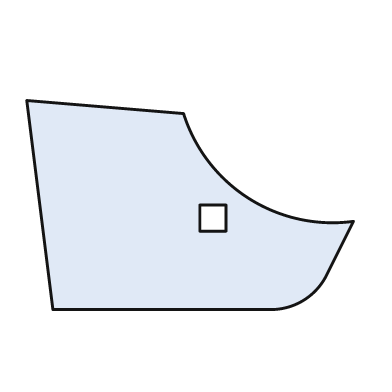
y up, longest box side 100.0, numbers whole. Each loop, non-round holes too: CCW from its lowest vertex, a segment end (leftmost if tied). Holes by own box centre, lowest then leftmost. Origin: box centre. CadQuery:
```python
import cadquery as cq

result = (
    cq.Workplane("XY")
    .moveTo(-42.0, -32.0)
    .lineTo(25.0, -32.0)
    .threePointArc((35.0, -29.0), (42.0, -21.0))
    .lineTo(50.0, -5.0)
    .threePointArc((18.0, 2.0), (-2.0, 28.0))
    .lineTo(-50.0, 32.0)
    .close()
    .moveTo(3.0, -8.0)
    .lineTo(11.0, -8.0)
    .lineTo(11.0, 0.0)
    .lineTo(3.0, 0.0)
    .close()
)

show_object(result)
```